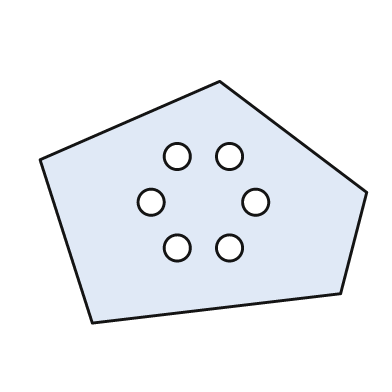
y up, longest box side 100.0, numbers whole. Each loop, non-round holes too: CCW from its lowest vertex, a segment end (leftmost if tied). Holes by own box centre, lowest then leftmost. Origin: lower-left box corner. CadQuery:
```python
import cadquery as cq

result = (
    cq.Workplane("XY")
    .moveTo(16.0, 0.0)
    .lineTo(92.0, 9.0)
    .lineTo(100.0, 40.0)
    .lineTo(55.0, 74.0)
    .lineTo(0.0, 50.0)
    .close()
    .moveTo(42.0, 23.0)
    .circle(4.0)
    .moveTo(58.0, 23.0)
    .circle(4.0)
    .moveTo(34.0, 37.0)
    .circle(4.0)
    .moveTo(66.0, 37.0)
    .circle(4.0)
    .moveTo(42.0, 51.0)
    .circle(4.0)
    .moveTo(58.0, 51.0)
    .circle(4.0)
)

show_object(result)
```